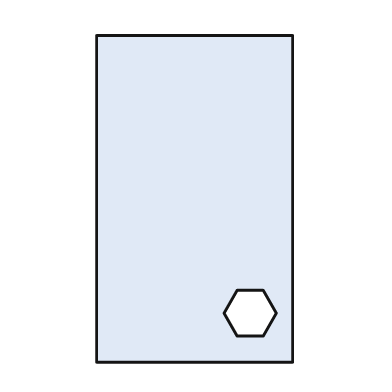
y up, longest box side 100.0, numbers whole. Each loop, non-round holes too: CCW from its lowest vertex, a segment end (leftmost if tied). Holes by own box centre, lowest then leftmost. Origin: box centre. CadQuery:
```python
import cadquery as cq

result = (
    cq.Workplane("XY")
    .moveTo(-30.0, -50.0)
    .lineTo(30.0, -50.0)
    .lineTo(30.0, 50.0)
    .lineTo(-30.0, 50.0)
    .close()
    .moveTo(13.0, -42.0)
    .lineTo(21.0, -42.0)
    .lineTo(25.0, -35.0)
    .lineTo(21.0, -28.0)
    .lineTo(13.0, -28.0)
    .lineTo(9.0, -35.0)
    .close()
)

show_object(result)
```